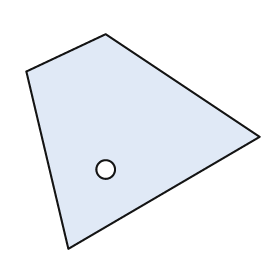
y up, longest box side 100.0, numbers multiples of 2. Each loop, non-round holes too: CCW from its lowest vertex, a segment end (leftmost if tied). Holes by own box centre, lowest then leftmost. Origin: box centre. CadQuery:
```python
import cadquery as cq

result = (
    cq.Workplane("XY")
    .moveTo(-32.0, -46.0)
    .lineTo(50.0, 2.0)
    .lineTo(-16.0, 46.0)
    .lineTo(-50.0, 30.0)
    .close()
    .moveTo(-16.0, -12.0)
    .circle(4.0)
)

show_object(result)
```